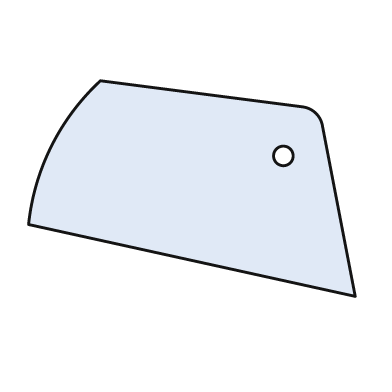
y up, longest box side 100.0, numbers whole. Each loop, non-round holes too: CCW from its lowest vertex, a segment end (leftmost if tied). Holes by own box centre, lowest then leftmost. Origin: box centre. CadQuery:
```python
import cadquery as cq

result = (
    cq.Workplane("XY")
    .moveTo(50.0, -33.0)
    .lineTo(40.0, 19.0)
    .threePointArc((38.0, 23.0), (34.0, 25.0))
    .lineTo(-28.0, 33.0)
    .threePointArc((-43.0, 13.0), (-50.0, -11.0))
    .close()
    .moveTo(28.0, 10.0)
    .circle(3.0)
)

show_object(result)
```